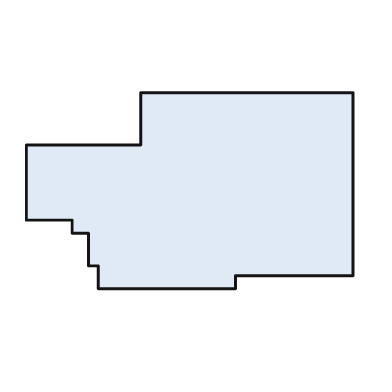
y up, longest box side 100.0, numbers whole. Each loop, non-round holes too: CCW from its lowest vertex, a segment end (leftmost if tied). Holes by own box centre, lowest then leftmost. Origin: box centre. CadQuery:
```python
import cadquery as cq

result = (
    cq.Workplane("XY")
    .moveTo(-28.0, -30.0)
    .lineTo(14.0, -30.0)
    .lineTo(14.0, -26.0)
    .lineTo(50.0, -26.0)
    .lineTo(50.0, 30.0)
    .lineTo(-15.0, 30.0)
    .lineTo(-15.0, 14.0)
    .lineTo(-50.0, 14.0)
    .lineTo(-50.0, -9.0)
    .lineTo(-36.0, -9.0)
    .lineTo(-36.0, -13.0)
    .lineTo(-31.0, -13.0)
    .lineTo(-31.0, -23.0)
    .lineTo(-28.0, -23.0)
    .close()
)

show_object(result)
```